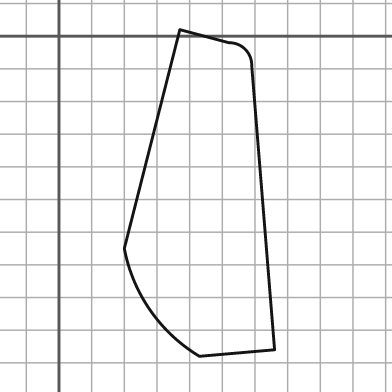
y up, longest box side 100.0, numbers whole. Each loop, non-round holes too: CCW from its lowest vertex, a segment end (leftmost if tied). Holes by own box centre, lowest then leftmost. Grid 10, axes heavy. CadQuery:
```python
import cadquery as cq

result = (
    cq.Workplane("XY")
    .moveTo(43.0, -98.0)
    .lineTo(66.0, -96.0)
    .lineTo(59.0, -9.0)
    .threePointArc((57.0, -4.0), (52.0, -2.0))
    .lineTo(37.0, 2.0)
    .lineTo(20.0, -65.0)
    .threePointArc((28.0, -84.0), (43.0, -98.0))
    .close()
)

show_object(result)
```